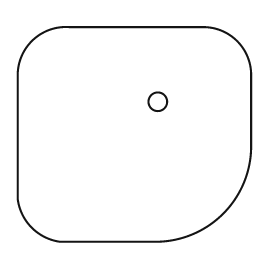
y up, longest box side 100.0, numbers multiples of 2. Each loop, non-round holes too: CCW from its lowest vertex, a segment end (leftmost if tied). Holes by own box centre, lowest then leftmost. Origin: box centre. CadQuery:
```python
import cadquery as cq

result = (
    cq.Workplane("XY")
    .moveTo(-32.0, -46.0)
    .lineTo(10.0, -46.0)
    .threePointArc((38.0, -34.0), (50.0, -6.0))
    .lineTo(50.0, 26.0)
    .threePointArc((44.0, 40.0), (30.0, 46.0))
    .lineTo(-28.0, 46.0)
    .threePointArc((-44.0, 40.0), (-50.0, 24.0))
    .lineTo(-50.0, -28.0)
    .threePointArc((-44.0, -40.0), (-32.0, -46.0))
    .close()
    .moveTo(10.0, 14.0)
    .circle(4.0)
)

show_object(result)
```